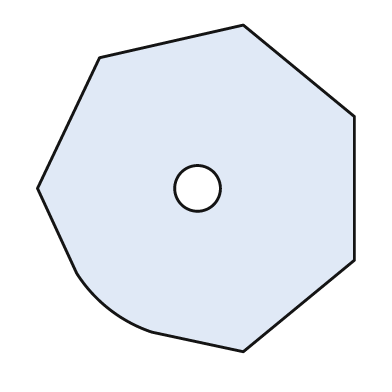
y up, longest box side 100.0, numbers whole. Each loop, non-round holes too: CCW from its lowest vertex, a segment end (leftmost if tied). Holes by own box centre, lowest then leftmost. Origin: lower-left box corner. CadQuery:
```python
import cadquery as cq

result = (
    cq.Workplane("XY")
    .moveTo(63.0, 0.0)
    .lineTo(97.0, 28.0)
    .lineTo(97.0, 72.0)
    .lineTo(63.0, 100.0)
    .lineTo(19.0, 90.0)
    .lineTo(0.0, 50.0)
    .lineTo(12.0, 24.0)
    .threePointArc((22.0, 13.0), (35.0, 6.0))
    .close()
    .moveTo(49.0, 50.0)
    .circle(7.0)
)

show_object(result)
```